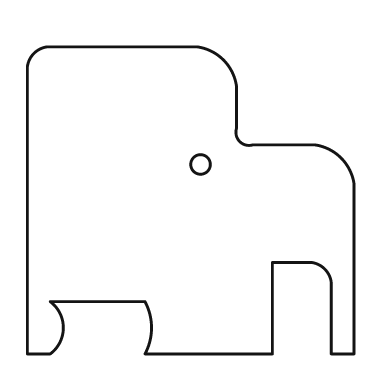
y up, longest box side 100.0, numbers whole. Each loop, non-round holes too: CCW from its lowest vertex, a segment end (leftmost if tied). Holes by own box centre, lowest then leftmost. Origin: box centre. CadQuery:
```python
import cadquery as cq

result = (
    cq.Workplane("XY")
    .moveTo(-50.0, -47.0)
    .lineTo(-43.0, -47.0)
    .threePointArc((-39.0, -39.0), (-43.0, -31.0))
    .lineTo(-14.0, -31.0)
    .threePointArc((-12.0, -39.0), (-14.0, -47.0))
    .lineTo(25.0, -47.0)
    .lineTo(25.0, -19.0)
    .lineTo(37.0, -19.0)
    .threePointArc((41.0, -21.0), (43.0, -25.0))
    .lineTo(43.0, -47.0)
    .lineTo(50.0, -47.0)
    .lineTo(50.0, 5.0)
    .threePointArc((46.0, 13.0), (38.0, 17.0))
    .lineTo(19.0, 17.0)
    .threePointArc((15.0, 18.0), (14.0, 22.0))
    .lineTo(14.0, 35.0)
    .threePointArc((10.0, 43.0), (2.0, 47.0))
    .lineTo(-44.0, 47.0)
    .threePointArc((-48.0, 45.0), (-50.0, 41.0))
    .close()
    .moveTo(3.0, 11.0)
    .circle(3.0)
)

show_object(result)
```